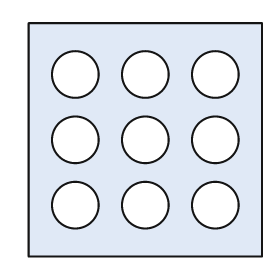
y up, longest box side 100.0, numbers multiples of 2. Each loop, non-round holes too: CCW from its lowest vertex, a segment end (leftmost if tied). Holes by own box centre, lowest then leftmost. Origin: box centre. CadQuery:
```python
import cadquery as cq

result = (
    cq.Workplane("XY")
    .moveTo(-50.0, -50.0)
    .lineTo(50.0, -50.0)
    .lineTo(50.0, 50.0)
    .lineTo(-50.0, 50.0)
    .close()
    .moveTo(-30.0, -28.0)
    .circle(10.0)
    .moveTo(0.0, -28.0)
    .circle(10.0)
    .moveTo(30.0, -28.0)
    .circle(10.0)
    .moveTo(-30.0, 0.0)
    .circle(10.0)
    .moveTo(0.0, 0.0)
    .circle(10.0)
    .moveTo(30.0, 0.0)
    .circle(10.0)
    .moveTo(-30.0, 28.0)
    .circle(10.0)
    .moveTo(0.0, 28.0)
    .circle(10.0)
    .moveTo(30.0, 28.0)
    .circle(10.0)
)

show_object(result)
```